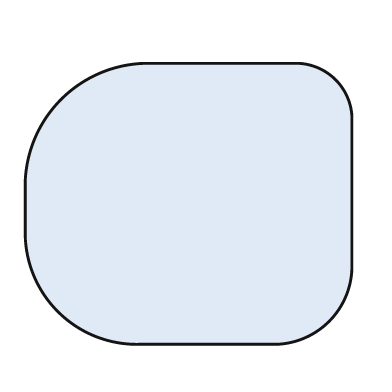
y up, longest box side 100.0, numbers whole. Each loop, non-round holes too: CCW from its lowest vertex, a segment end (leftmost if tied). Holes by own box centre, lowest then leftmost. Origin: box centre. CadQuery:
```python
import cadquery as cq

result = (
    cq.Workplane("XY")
    .moveTo(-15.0, -43.0)
    .lineTo(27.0, -43.0)
    .threePointArc((43.0, -36.0), (50.0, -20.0))
    .lineTo(50.0, 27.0)
    .threePointArc((45.0, 38.0), (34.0, 43.0))
    .lineTo(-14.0, 43.0)
    .threePointArc((-39.0, 32.0), (-50.0, 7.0))
    .lineTo(-50.0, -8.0)
    .threePointArc((-40.0, -33.0), (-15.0, -43.0))
    .close()
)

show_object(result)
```